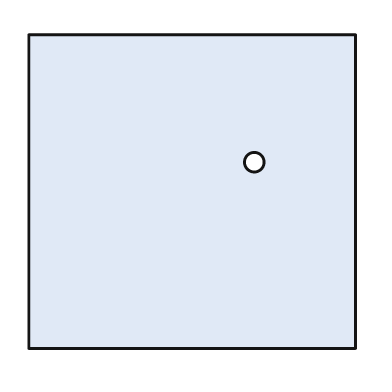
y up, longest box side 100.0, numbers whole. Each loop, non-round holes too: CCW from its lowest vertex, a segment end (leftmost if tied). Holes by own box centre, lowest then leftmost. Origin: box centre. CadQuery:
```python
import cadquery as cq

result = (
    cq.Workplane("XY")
    .moveTo(-50.0, -48.0)
    .lineTo(50.0, -48.0)
    .lineTo(50.0, 48.0)
    .lineTo(-50.0, 48.0)
    .close()
    .moveTo(19.0, 9.0)
    .circle(3.0)
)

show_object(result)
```